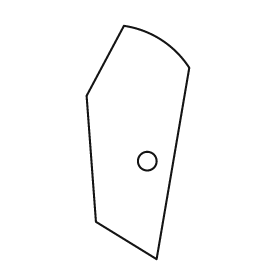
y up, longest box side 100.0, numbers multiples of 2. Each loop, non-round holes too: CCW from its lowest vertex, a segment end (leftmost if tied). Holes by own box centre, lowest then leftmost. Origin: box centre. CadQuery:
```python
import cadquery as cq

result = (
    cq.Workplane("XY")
    .moveTo(8.0, -50.0)
    .lineTo(22.0, 32.0)
    .threePointArc((10.0, 44.0), (-6.0, 50.0))
    .lineTo(-22.0, 20.0)
    .lineTo(-18.0, -34.0)
    .close()
    .moveTo(4.0, -8.0)
    .circle(4.0)
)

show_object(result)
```